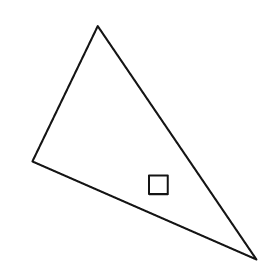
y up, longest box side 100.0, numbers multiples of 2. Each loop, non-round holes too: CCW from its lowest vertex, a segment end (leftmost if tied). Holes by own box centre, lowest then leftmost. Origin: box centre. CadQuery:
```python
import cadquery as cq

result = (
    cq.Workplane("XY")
    .moveTo(48.0, -50.0)
    .lineTo(-20.0, 50.0)
    .lineTo(-48.0, -8.0)
    .close()
    .moveTo(2.0, -22.0)
    .lineTo(10.0, -22.0)
    .lineTo(10.0, -14.0)
    .lineTo(2.0, -14.0)
    .close()
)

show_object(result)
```